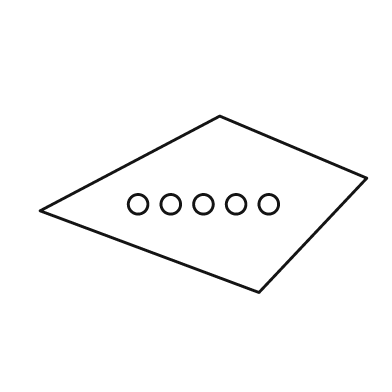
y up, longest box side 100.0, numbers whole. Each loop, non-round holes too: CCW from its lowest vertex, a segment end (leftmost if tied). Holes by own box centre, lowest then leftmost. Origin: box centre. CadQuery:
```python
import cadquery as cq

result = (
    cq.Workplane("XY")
    .moveTo(17.0, -27.0)
    .lineTo(50.0, 8.0)
    .lineTo(5.0, 27.0)
    .lineTo(-50.0, -2.0)
    .close()
    .moveTo(-20.0, 0.0)
    .circle(3.0)
    .moveTo(-10.0, 0.0)
    .circle(3.0)
    .moveTo(0.0, 0.0)
    .circle(3.0)
    .moveTo(10.0, 0.0)
    .circle(3.0)
    .moveTo(20.0, 0.0)
    .circle(3.0)
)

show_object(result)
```